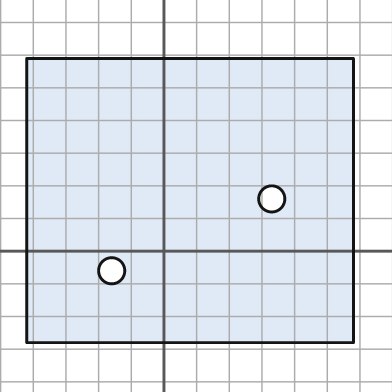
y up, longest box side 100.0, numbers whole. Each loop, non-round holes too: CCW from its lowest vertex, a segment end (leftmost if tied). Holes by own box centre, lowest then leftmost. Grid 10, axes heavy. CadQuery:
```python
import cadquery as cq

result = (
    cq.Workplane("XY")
    .moveTo(-42.0, -28.0)
    .lineTo(58.0, -28.0)
    .lineTo(58.0, 59.0)
    .lineTo(-42.0, 59.0)
    .close()
    .moveTo(-16.0, -6.0)
    .circle(4.0)
    .moveTo(33.0, 16.0)
    .circle(4.0)
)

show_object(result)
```